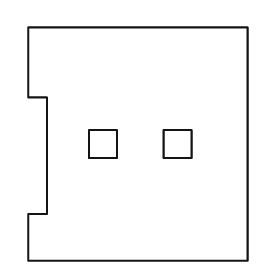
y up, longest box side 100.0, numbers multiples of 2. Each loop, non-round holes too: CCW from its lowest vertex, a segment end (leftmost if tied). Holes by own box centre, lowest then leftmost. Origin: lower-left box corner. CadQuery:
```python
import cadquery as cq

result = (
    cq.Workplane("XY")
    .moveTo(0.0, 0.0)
    .lineTo(94.0, 0.0)
    .lineTo(94.0, 100.0)
    .lineTo(0.0, 100.0)
    .lineTo(0.0, 70.0)
    .lineTo(8.0, 70.0)
    .lineTo(8.0, 20.0)
    .lineTo(0.0, 20.0)
    .close()
    .moveTo(26.0, 44.0)
    .lineTo(38.0, 44.0)
    .lineTo(38.0, 56.0)
    .lineTo(26.0, 56.0)
    .close()
    .moveTo(58.0, 44.0)
    .lineTo(70.0, 44.0)
    .lineTo(70.0, 56.0)
    .lineTo(58.0, 56.0)
    .close()
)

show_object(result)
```